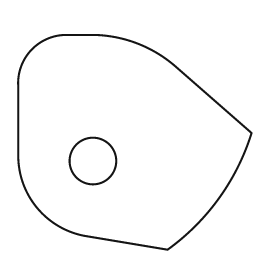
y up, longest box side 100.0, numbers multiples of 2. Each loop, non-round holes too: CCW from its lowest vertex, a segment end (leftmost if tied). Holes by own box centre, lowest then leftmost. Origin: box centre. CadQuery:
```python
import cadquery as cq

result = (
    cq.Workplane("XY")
    .moveTo(14.0, -46.0)
    .threePointArc((36.0, -24.0), (50.0, 4.0))
    .lineTo(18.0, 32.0)
    .threePointArc((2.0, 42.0), (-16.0, 46.0))
    .lineTo(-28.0, 46.0)
    .threePointArc((-44.0, 40.0), (-50.0, 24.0))
    .lineTo(-50.0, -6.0)
    .threePointArc((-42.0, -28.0), (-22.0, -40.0))
    .close()
    .moveTo(-18.0, -8.0)
    .circle(10.0)
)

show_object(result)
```